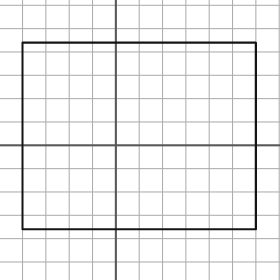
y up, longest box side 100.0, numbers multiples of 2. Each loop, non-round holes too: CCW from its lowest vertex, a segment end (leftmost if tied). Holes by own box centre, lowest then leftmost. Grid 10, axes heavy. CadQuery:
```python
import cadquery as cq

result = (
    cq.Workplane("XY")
    .moveTo(-40.0, -36.0)
    .lineTo(60.0, -36.0)
    .lineTo(60.0, 44.0)
    .lineTo(-40.0, 44.0)
    .close()
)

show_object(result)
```